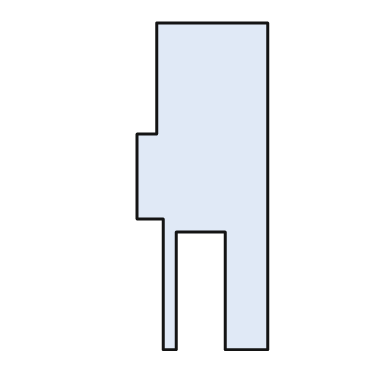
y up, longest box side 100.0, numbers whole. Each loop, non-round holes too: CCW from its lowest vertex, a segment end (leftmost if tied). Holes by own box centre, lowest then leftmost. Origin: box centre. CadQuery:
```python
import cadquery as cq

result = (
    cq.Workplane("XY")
    .moveTo(-12.0, -50.0)
    .lineTo(-8.0, -50.0)
    .lineTo(-8.0, -14.0)
    .lineTo(7.0, -14.0)
    .lineTo(7.0, -50.0)
    .lineTo(20.0, -50.0)
    .lineTo(20.0, 50.0)
    .lineTo(-14.0, 50.0)
    .lineTo(-14.0, 16.0)
    .lineTo(-20.0, 16.0)
    .lineTo(-20.0, -10.0)
    .lineTo(-12.0, -10.0)
    .close()
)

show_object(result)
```